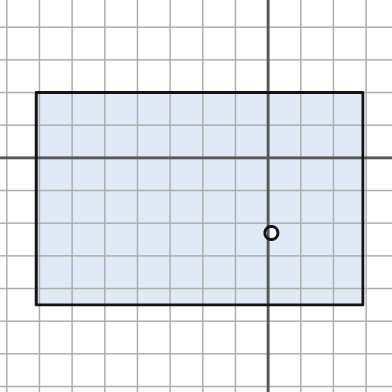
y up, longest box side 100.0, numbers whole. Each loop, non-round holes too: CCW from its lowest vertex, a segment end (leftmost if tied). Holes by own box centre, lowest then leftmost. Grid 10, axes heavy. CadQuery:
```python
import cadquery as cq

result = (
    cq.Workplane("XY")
    .moveTo(-71.0, -45.0)
    .lineTo(29.0, -45.0)
    .lineTo(29.0, 20.0)
    .lineTo(-71.0, 20.0)
    .close()
    .moveTo(1.0, -23.0)
    .circle(2.0)
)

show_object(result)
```